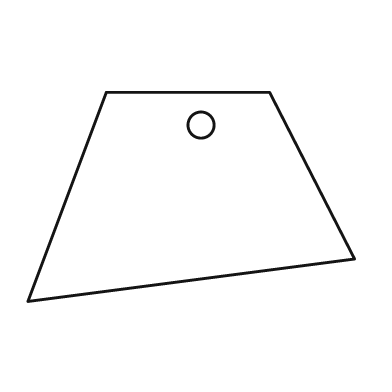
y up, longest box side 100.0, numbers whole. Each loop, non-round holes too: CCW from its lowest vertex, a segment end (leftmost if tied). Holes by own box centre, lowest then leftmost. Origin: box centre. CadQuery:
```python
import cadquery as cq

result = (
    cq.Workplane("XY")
    .moveTo(-50.0, -32.0)
    .lineTo(50.0, -19.0)
    .lineTo(24.0, 32.0)
    .lineTo(-26.0, 32.0)
    .close()
    .moveTo(3.0, 22.0)
    .circle(4.0)
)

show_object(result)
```